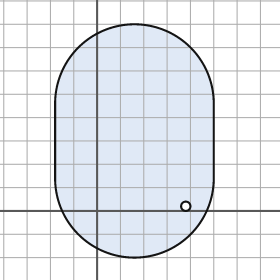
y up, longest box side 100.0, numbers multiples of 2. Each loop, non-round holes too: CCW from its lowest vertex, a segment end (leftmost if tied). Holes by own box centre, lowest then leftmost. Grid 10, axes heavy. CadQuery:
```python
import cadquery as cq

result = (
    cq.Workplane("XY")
    .moveTo(-18.0, 14.0)
    .threePointArc((16.0, -20.0), (50.0, 14.0))
    .lineTo(50.0, 46.0)
    .threePointArc((16.0, 80.0), (-18.0, 46.0))
    .close()
    .moveTo(38.0, 2.0)
    .circle(2.0)
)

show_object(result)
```